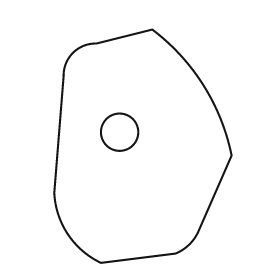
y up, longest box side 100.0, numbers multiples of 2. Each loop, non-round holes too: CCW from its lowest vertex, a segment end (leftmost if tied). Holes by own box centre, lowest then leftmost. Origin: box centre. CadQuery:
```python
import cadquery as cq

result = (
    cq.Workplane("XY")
    .moveTo(-18.0, -50.0)
    .lineTo(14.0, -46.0)
    .threePointArc((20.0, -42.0), (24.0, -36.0))
    .lineTo(38.0, -4.0)
    .threePointArc((26.0, 26.0), (4.0, 50.0))
    .lineTo(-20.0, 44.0)
    .threePointArc((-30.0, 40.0), (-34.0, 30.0))
    .lineTo(-38.0, -20.0)
    .threePointArc((-32.0, -38.0), (-18.0, -50.0))
    .close()
    .moveTo(-10.0, 6.0)
    .circle(8.0)
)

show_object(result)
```